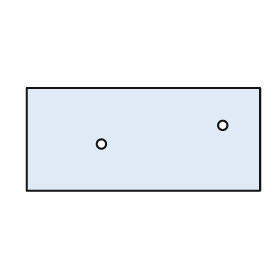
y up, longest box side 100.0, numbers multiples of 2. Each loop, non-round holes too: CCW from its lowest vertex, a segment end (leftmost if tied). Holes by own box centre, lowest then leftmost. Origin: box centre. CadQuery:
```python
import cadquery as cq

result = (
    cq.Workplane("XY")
    .moveTo(-50.0, -22.0)
    .lineTo(50.0, -22.0)
    .lineTo(50.0, 22.0)
    .lineTo(-50.0, 22.0)
    .close()
    .moveTo(-18.0, -2.0)
    .circle(2.0)
    .moveTo(34.0, 6.0)
    .circle(2.0)
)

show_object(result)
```